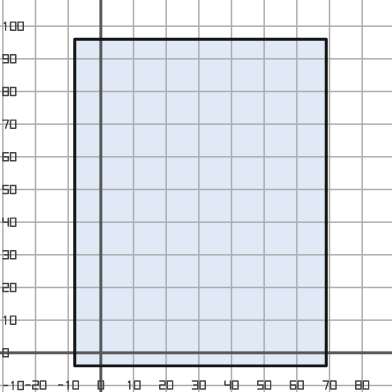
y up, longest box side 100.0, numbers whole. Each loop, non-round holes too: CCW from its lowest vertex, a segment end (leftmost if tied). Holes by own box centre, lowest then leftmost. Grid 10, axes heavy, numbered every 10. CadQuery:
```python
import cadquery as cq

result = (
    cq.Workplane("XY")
    .moveTo(-8.0, -4.0)
    .lineTo(69.0, -4.0)
    .lineTo(69.0, 96.0)
    .lineTo(-8.0, 96.0)
    .close()
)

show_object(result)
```